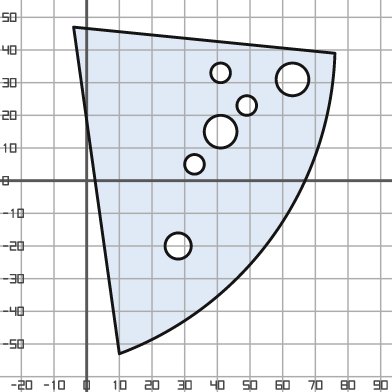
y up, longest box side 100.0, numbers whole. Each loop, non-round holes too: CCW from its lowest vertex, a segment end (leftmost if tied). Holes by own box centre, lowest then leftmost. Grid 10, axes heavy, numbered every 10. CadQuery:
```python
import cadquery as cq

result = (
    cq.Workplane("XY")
    .moveTo(10.0, -53.0)
    .threePointArc((57.0, -17.0), (76.0, 39.0))
    .lineTo(-4.0, 47.0)
    .close()
    .moveTo(28.0, -20.0)
    .circle(4.0)
    .moveTo(33.0, 5.0)
    .circle(3.0)
    .moveTo(41.0, 15.0)
    .circle(5.0)
    .moveTo(49.0, 23.0)
    .circle(3.0)
    .moveTo(63.0, 31.0)
    .circle(5.0)
    .moveTo(41.0, 33.0)
    .circle(3.0)
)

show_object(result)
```